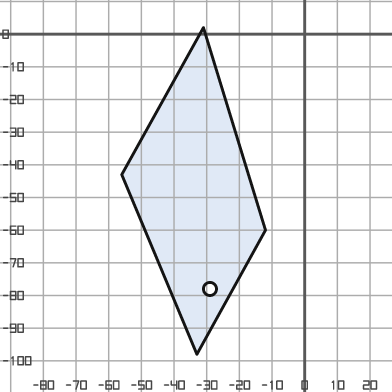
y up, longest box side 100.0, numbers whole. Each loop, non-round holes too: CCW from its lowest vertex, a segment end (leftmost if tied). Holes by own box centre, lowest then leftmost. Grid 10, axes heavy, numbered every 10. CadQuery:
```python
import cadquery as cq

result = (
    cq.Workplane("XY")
    .moveTo(-33.0, -98.0)
    .lineTo(-12.0, -60.0)
    .lineTo(-31.0, 2.0)
    .lineTo(-56.0, -43.0)
    .close()
    .moveTo(-29.0, -78.0)
    .circle(2.0)
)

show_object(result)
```